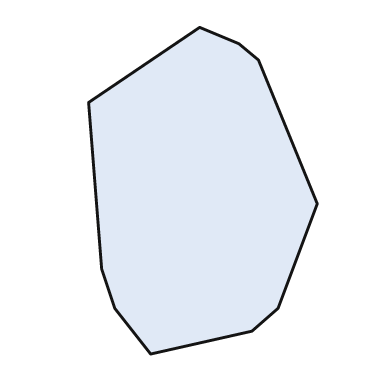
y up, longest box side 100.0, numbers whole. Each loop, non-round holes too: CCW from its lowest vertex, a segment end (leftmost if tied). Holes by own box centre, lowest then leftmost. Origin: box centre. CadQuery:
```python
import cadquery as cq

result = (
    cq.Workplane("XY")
    .moveTo(-16.0, -50.0)
    .lineTo(15.0, -43.0)
    .lineTo(23.0, -36.0)
    .lineTo(35.0, -4.0)
    .lineTo(17.0, 40.0)
    .lineTo(11.0, 45.0)
    .lineTo(-1.0, 50.0)
    .lineTo(-35.0, 27.0)
    .lineTo(-31.0, -24.0)
    .lineTo(-27.0, -36.0)
    .close()
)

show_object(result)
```